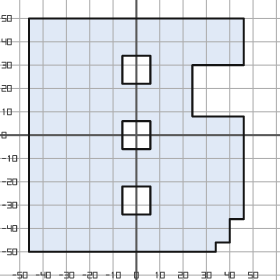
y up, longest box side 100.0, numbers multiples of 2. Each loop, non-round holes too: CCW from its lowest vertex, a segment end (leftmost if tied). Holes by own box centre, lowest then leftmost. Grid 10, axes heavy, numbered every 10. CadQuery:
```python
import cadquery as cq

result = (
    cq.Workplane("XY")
    .moveTo(-46.0, -50.0)
    .lineTo(34.0, -50.0)
    .lineTo(34.0, -46.0)
    .lineTo(40.0, -46.0)
    .lineTo(40.0, -36.0)
    .lineTo(46.0, -36.0)
    .lineTo(46.0, 8.0)
    .lineTo(24.0, 8.0)
    .lineTo(24.0, 30.0)
    .lineTo(46.0, 30.0)
    .lineTo(46.0, 50.0)
    .lineTo(-46.0, 50.0)
    .close()
    .moveTo(-6.0, -34.0)
    .lineTo(6.0, -34.0)
    .lineTo(6.0, -22.0)
    .lineTo(-6.0, -22.0)
    .close()
    .moveTo(-6.0, -6.0)
    .lineTo(6.0, -6.0)
    .lineTo(6.0, 6.0)
    .lineTo(-6.0, 6.0)
    .close()
    .moveTo(-6.0, 22.0)
    .lineTo(6.0, 22.0)
    .lineTo(6.0, 34.0)
    .lineTo(-6.0, 34.0)
    .close()
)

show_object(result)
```